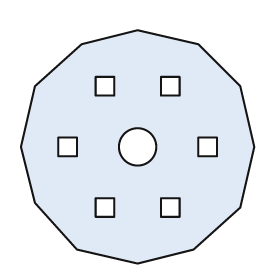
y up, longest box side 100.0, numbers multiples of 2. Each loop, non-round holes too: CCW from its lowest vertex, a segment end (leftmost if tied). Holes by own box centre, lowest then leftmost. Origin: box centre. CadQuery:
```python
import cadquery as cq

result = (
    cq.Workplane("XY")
    .moveTo(0.0, -50.0)
    .lineTo(24.0, -44.0)
    .lineTo(44.0, -26.0)
    .lineTo(50.0, 0.0)
    .lineTo(44.0, 26.0)
    .lineTo(26.0, 44.0)
    .lineTo(0.0, 50.0)
    .lineTo(-24.0, 44.0)
    .lineTo(-44.0, 26.0)
    .lineTo(-50.0, 0.0)
    .lineTo(-44.0, -24.0)
    .lineTo(-26.0, -44.0)
    .close()
    .moveTo(-18.0, -30.0)
    .lineTo(-10.0, -30.0)
    .lineTo(-10.0, -22.0)
    .lineTo(-18.0, -22.0)
    .close()
    .moveTo(10.0, -30.0)
    .lineTo(18.0, -30.0)
    .lineTo(18.0, -22.0)
    .lineTo(10.0, -22.0)
    .close()
    .moveTo(-34.0, -4.0)
    .lineTo(-26.0, -4.0)
    .lineTo(-26.0, 4.0)
    .lineTo(-34.0, 4.0)
    .close()
    .moveTo(0.0, 0.0)
    .circle(8.0)
    .moveTo(26.0, -4.0)
    .lineTo(34.0, -4.0)
    .lineTo(34.0, 4.0)
    .lineTo(26.0, 4.0)
    .close()
    .moveTo(-18.0, 22.0)
    .lineTo(-10.0, 22.0)
    .lineTo(-10.0, 30.0)
    .lineTo(-18.0, 30.0)
    .close()
    .moveTo(10.0, 22.0)
    .lineTo(18.0, 22.0)
    .lineTo(18.0, 30.0)
    .lineTo(10.0, 30.0)
    .close()
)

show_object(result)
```